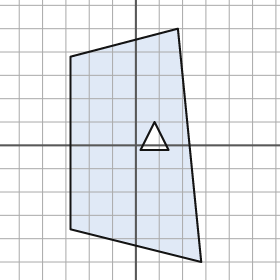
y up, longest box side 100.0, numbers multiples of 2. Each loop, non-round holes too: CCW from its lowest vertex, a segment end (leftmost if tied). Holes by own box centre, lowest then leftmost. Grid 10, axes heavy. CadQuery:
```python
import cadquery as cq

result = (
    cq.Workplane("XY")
    .moveTo(28.0, -50.0)
    .lineTo(18.0, 50.0)
    .lineTo(-28.0, 38.0)
    .lineTo(-28.0, -36.0)
    .close()
    .moveTo(2.0, -2.0)
    .lineTo(14.0, -2.0)
    .lineTo(8.0, 10.0)
    .close()
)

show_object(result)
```